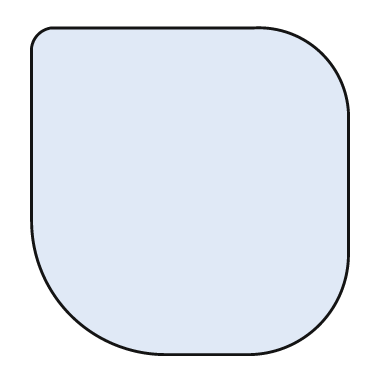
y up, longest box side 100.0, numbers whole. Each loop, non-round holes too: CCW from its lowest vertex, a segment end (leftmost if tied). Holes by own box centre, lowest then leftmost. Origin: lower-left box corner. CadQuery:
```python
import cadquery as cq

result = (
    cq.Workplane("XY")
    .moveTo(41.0, 0.0)
    .lineTo(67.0, 0.0)
    .threePointArc((88.0, 9.0), (97.0, 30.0))
    .lineTo(97.0, 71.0)
    .threePointArc((89.0, 92.0), (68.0, 100.0))
    .lineTo(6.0, 100.0)
    .threePointArc((2.0, 98.0), (0.0, 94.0))
    .lineTo(0.0, 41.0)
    .threePointArc((12.0, 12.0), (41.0, 0.0))
    .close()
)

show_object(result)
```